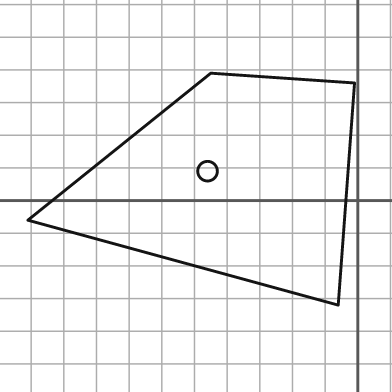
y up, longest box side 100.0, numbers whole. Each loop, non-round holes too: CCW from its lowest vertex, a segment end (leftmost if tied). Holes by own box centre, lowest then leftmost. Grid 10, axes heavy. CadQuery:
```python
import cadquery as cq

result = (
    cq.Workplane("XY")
    .moveTo(-6.0, -32.0)
    .lineTo(-1.0, 36.0)
    .lineTo(-45.0, 39.0)
    .lineTo(-101.0, -6.0)
    .close()
    .moveTo(-46.0, 9.0)
    .circle(3.0)
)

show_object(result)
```